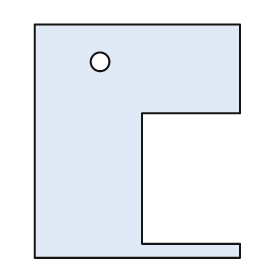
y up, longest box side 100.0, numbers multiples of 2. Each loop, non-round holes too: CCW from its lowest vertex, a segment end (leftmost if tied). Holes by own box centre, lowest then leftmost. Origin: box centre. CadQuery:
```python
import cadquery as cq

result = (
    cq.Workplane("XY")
    .moveTo(-44.0, -50.0)
    .lineTo(44.0, -50.0)
    .lineTo(44.0, -44.0)
    .lineTo(2.0, -44.0)
    .lineTo(2.0, 12.0)
    .lineTo(44.0, 12.0)
    .lineTo(44.0, 50.0)
    .lineTo(-44.0, 50.0)
    .close()
    .moveTo(-16.0, 34.0)
    .circle(4.0)
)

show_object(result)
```